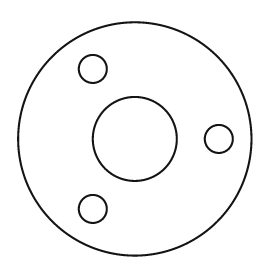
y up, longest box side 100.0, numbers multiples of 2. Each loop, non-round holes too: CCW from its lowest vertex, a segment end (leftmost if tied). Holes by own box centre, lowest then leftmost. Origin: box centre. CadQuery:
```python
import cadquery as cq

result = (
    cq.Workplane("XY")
    .moveTo(0.0, 0.0)
    .circle(50.0)
    .moveTo(-18.0, -30.0)
    .circle(6.0)
    .moveTo(0.0, 0.0)
    .circle(18.0)
    .moveTo(36.0, 0.0)
    .circle(6.0)
    .moveTo(-18.0, 30.0)
    .circle(6.0)
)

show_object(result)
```